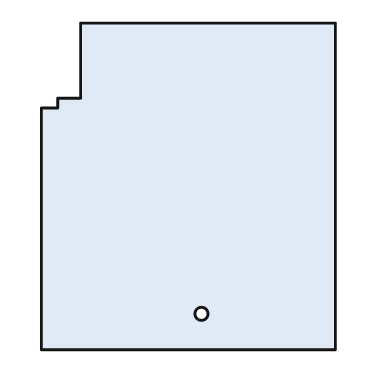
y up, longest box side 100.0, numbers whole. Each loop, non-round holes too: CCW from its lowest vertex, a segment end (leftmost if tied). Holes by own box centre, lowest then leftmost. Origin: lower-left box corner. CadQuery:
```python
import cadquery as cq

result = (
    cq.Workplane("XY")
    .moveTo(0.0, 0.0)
    .lineTo(90.0, 0.0)
    .lineTo(90.0, 100.0)
    .lineTo(12.0, 100.0)
    .lineTo(12.0, 77.0)
    .lineTo(5.0, 77.0)
    .lineTo(5.0, 74.0)
    .lineTo(0.0, 74.0)
    .close()
    .moveTo(49.0, 11.0)
    .circle(2.0)
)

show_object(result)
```